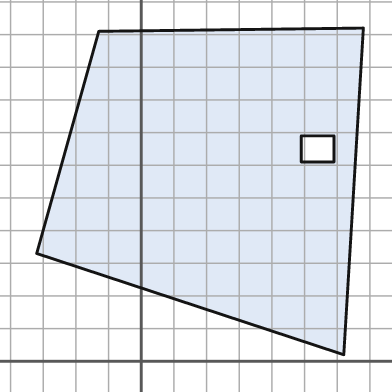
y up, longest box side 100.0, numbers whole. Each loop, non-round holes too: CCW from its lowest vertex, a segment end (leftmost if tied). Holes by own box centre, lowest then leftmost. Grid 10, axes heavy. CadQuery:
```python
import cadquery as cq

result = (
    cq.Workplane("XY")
    .moveTo(62.0, 2.0)
    .lineTo(68.0, 102.0)
    .lineTo(-13.0, 101.0)
    .lineTo(-32.0, 33.0)
    .close()
    .moveTo(49.0, 61.0)
    .lineTo(59.0, 61.0)
    .lineTo(59.0, 69.0)
    .lineTo(49.0, 69.0)
    .close()
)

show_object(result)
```